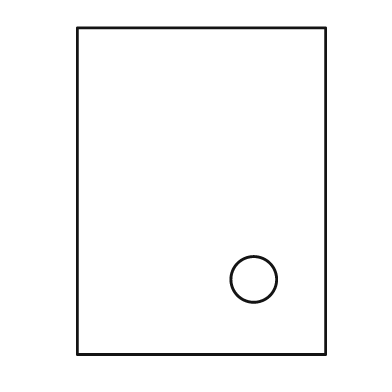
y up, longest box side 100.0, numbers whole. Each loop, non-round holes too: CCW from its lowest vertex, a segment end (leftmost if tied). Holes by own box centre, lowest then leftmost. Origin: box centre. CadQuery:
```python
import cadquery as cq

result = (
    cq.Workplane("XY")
    .moveTo(-38.0, -50.0)
    .lineTo(38.0, -50.0)
    .lineTo(38.0, 50.0)
    .lineTo(-38.0, 50.0)
    .close()
    .moveTo(16.0, -27.0)
    .circle(7.0)
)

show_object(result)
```